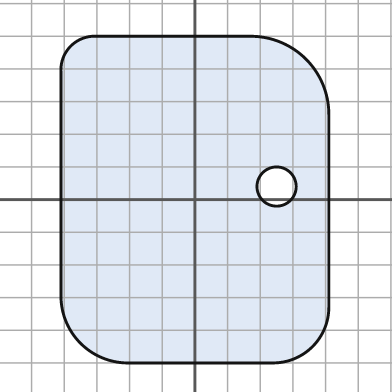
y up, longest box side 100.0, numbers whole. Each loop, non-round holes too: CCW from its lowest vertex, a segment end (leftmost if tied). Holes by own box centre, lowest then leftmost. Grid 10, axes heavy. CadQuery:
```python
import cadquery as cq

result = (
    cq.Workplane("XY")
    .moveTo(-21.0, -50.0)
    .lineTo(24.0, -50.0)
    .threePointArc((36.0, -45.0), (41.0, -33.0))
    .lineTo(41.0, 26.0)
    .threePointArc((34.0, 43.0), (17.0, 50.0))
    .lineTo(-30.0, 50.0)
    .threePointArc((-38.0, 47.0), (-41.0, 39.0))
    .lineTo(-41.0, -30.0)
    .threePointArc((-35.0, -44.0), (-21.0, -50.0))
    .close()
    .moveTo(25.0, 4.0)
    .circle(6.0)
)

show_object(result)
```